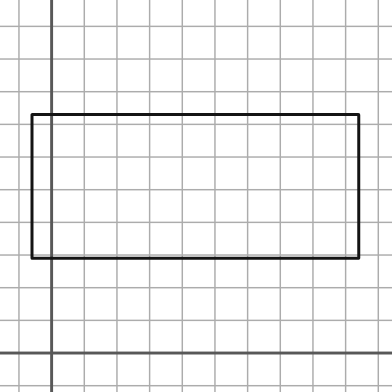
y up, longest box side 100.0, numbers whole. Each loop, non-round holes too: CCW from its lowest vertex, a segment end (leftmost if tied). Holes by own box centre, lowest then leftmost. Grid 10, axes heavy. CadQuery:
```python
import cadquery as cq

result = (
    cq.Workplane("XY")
    .moveTo(-6.0, 29.0)
    .lineTo(94.0, 29.0)
    .lineTo(94.0, 73.0)
    .lineTo(-6.0, 73.0)
    .close()
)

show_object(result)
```